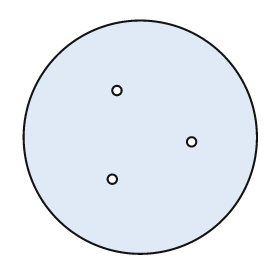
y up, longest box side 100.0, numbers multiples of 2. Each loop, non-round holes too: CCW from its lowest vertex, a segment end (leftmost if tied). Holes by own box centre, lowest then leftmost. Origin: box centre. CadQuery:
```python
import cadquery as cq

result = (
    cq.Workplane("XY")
    .moveTo(0.0, 0.0)
    .circle(50.0)
    .moveTo(-12.0, -18.0)
    .circle(2.0)
    .moveTo(22.0, -2.0)
    .circle(2.0)
    .moveTo(-10.0, 20.0)
    .circle(2.0)
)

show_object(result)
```